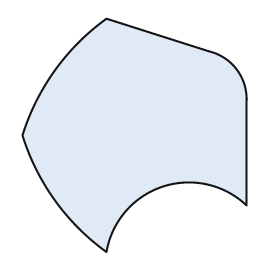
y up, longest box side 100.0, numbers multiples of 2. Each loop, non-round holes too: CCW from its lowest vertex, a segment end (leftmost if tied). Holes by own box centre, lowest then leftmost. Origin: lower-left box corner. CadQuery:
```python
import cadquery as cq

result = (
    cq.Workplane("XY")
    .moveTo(36.0, 0.0)
    .threePointArc((60.0, 28.0), (96.0, 20.0))
    .lineTo(96.0, 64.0)
    .threePointArc((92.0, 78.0), (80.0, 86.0))
    .lineTo(36.0, 100.0)
    .threePointArc((14.0, 78.0), (0.0, 50.0))
    .threePointArc((14.0, 22.0), (36.0, 0.0))
    .close()
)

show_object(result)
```